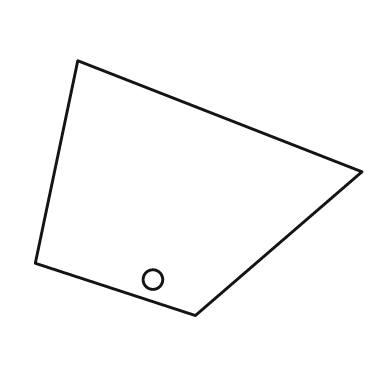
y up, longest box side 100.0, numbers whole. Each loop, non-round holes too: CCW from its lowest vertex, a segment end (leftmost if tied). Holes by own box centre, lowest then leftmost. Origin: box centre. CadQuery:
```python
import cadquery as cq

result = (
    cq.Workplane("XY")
    .moveTo(-1.0, -39.0)
    .lineTo(50.0, 5.0)
    .lineTo(-37.0, 39.0)
    .lineTo(-50.0, -23.0)
    .close()
    .moveTo(-14.0, -28.0)
    .circle(3.0)
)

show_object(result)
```